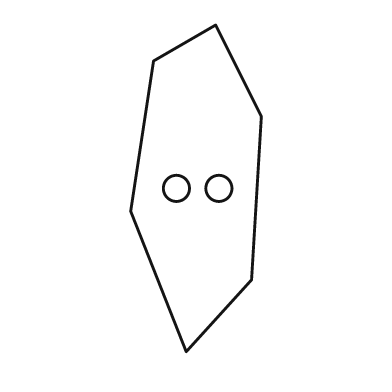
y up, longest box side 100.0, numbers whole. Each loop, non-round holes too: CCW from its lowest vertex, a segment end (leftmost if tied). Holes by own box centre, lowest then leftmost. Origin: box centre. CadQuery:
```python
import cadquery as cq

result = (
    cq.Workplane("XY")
    .moveTo(-3.0, -50.0)
    .lineTo(17.0, -28.0)
    .lineTo(20.0, 22.0)
    .lineTo(6.0, 50.0)
    .lineTo(-13.0, 39.0)
    .lineTo(-20.0, -7.0)
    .close()
    .moveTo(-6.0, 0.0)
    .circle(4.0)
    .moveTo(7.0, 0.0)
    .circle(4.0)
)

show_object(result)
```